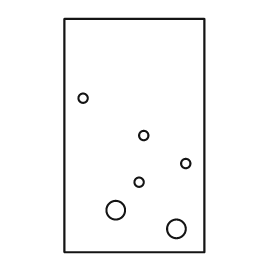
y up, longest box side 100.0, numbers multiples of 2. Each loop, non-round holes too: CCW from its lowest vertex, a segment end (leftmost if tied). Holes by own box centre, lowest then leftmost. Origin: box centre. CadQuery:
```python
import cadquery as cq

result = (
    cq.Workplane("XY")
    .moveTo(-30.0, -50.0)
    .lineTo(30.0, -50.0)
    .lineTo(30.0, 50.0)
    .lineTo(-30.0, 50.0)
    .close()
    .moveTo(18.0, -40.0)
    .circle(4.0)
    .moveTo(-8.0, -32.0)
    .circle(4.0)
    .moveTo(2.0, -20.0)
    .circle(2.0)
    .moveTo(22.0, -12.0)
    .circle(2.0)
    .moveTo(4.0, 0.0)
    .circle(2.0)
    .moveTo(-22.0, 16.0)
    .circle(2.0)
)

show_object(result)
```